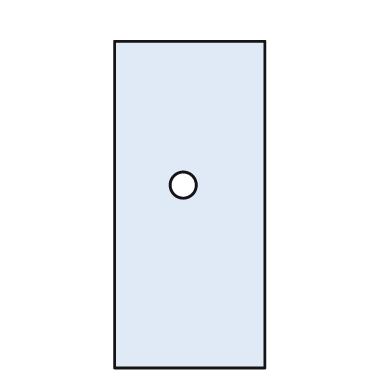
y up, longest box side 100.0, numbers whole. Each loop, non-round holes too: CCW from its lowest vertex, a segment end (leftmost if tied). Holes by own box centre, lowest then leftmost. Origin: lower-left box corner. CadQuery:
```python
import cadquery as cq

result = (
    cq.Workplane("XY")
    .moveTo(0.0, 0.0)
    .lineTo(46.0, 0.0)
    .lineTo(46.0, 100.0)
    .lineTo(0.0, 100.0)
    .close()
    .moveTo(21.0, 56.0)
    .circle(4.0)
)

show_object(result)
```